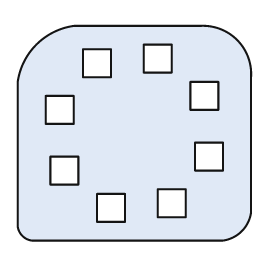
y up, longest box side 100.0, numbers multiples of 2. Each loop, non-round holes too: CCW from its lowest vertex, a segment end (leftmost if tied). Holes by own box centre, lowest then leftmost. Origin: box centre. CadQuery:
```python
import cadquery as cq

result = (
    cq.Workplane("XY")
    .moveTo(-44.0, -46.0)
    .lineTo(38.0, -46.0)
    .threePointArc((46.0, -42.0), (50.0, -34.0))
    .lineTo(50.0, 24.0)
    .threePointArc((44.0, 40.0), (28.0, 46.0))
    .lineTo(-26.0, 46.0)
    .threePointArc((-42.0, 38.0), (-50.0, 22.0))
    .lineTo(-50.0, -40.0)
    .threePointArc((-48.0, -44.0), (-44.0, -46.0))
    .close()
    .moveTo(-16.0, -38.0)
    .lineTo(-4.0, -38.0)
    .lineTo(-4.0, -26.0)
    .lineTo(-16.0, -26.0)
    .close()
    .moveTo(10.0, -36.0)
    .lineTo(22.0, -36.0)
    .lineTo(22.0, -24.0)
    .lineTo(10.0, -24.0)
    .close()
    .moveTo(-36.0, -22.0)
    .lineTo(-24.0, -22.0)
    .lineTo(-24.0, -10.0)
    .lineTo(-36.0, -10.0)
    .close()
    .moveTo(26.0, -16.0)
    .lineTo(38.0, -16.0)
    .lineTo(38.0, -4.0)
    .lineTo(26.0, -4.0)
    .close()
    .moveTo(-38.0, 4.0)
    .lineTo(-26.0, 4.0)
    .lineTo(-26.0, 16.0)
    .lineTo(-38.0, 16.0)
    .close()
    .moveTo(24.0, 10.0)
    .lineTo(36.0, 10.0)
    .lineTo(36.0, 22.0)
    .lineTo(24.0, 22.0)
    .close()
    .moveTo(-22.0, 24.0)
    .lineTo(-10.0, 24.0)
    .lineTo(-10.0, 36.0)
    .lineTo(-22.0, 36.0)
    .close()
    .moveTo(4.0, 26.0)
    .lineTo(16.0, 26.0)
    .lineTo(16.0, 38.0)
    .lineTo(4.0, 38.0)
    .close()
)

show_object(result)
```